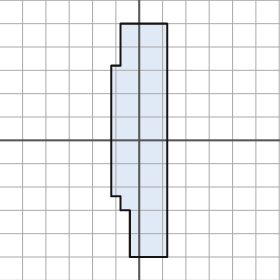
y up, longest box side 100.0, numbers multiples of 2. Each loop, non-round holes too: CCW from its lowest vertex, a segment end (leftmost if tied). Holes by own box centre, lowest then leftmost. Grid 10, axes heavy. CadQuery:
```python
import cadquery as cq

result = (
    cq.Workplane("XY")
    .moveTo(-4.0, -50.0)
    .lineTo(12.0, -50.0)
    .lineTo(12.0, 50.0)
    .lineTo(-8.0, 50.0)
    .lineTo(-8.0, 32.0)
    .lineTo(-12.0, 32.0)
    .lineTo(-12.0, -24.0)
    .lineTo(-8.0, -24.0)
    .lineTo(-8.0, -30.0)
    .lineTo(-4.0, -30.0)
    .close()
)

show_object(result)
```